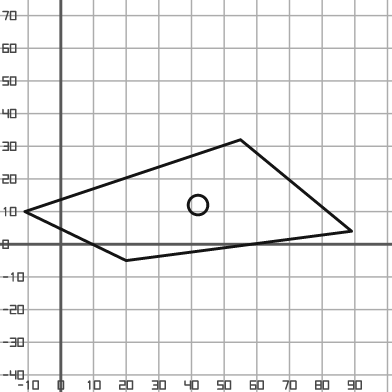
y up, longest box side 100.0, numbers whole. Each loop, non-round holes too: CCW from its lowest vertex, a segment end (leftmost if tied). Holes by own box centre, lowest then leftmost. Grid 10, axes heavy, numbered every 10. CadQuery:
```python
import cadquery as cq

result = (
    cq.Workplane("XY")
    .moveTo(20.0, -5.0)
    .lineTo(89.0, 4.0)
    .lineTo(55.0, 32.0)
    .lineTo(-11.0, 10.0)
    .close()
    .moveTo(42.0, 12.0)
    .circle(3.0)
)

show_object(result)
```